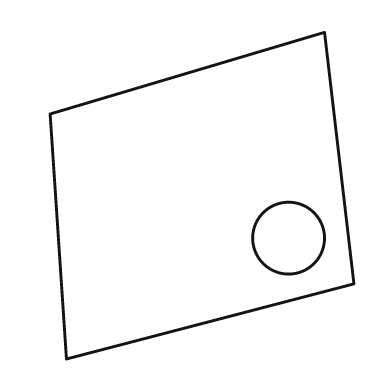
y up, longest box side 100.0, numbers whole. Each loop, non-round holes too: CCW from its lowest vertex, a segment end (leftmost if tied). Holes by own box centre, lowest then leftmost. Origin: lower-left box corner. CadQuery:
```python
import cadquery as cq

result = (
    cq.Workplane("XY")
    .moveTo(5.0, 0.0)
    .lineTo(93.0, 23.0)
    .lineTo(84.0, 100.0)
    .lineTo(0.0, 75.0)
    .close()
    .moveTo(73.0, 37.0)
    .circle(11.0)
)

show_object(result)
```